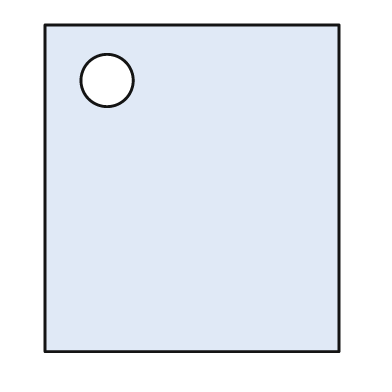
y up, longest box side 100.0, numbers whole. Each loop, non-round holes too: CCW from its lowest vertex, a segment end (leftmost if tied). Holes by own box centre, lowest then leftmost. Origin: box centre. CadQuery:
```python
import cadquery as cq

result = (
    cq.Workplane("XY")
    .moveTo(-45.0, -50.0)
    .lineTo(45.0, -50.0)
    .lineTo(45.0, 50.0)
    .lineTo(-45.0, 50.0)
    .close()
    .moveTo(-26.0, 33.0)
    .circle(8.0)
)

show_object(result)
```